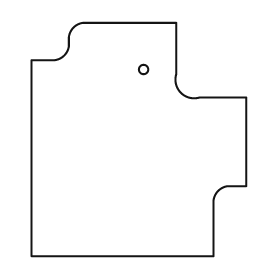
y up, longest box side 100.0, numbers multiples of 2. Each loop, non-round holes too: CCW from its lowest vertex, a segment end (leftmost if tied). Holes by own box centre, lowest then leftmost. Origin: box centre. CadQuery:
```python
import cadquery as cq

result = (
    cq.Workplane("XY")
    .moveTo(-46.0, -50.0)
    .lineTo(32.0, -50.0)
    .lineTo(32.0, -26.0)
    .threePointArc((34.0, -22.0), (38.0, -20.0))
    .lineTo(46.0, -20.0)
    .lineTo(46.0, 18.0)
    .lineTo(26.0, 18.0)
    .threePointArc((18.0, 20.0), (16.0, 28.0))
    .lineTo(16.0, 50.0)
    .lineTo(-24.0, 50.0)
    .threePointArc((-28.0, 48.0), (-30.0, 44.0))
    .lineTo(-30.0, 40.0)
    .threePointArc((-32.0, 36.0), (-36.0, 34.0))
    .lineTo(-46.0, 34.0)
    .close()
    .moveTo(2.0, 30.0)
    .circle(2.0)
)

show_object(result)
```